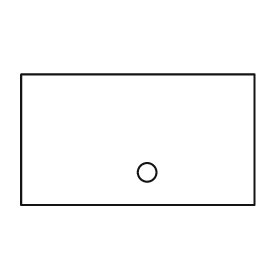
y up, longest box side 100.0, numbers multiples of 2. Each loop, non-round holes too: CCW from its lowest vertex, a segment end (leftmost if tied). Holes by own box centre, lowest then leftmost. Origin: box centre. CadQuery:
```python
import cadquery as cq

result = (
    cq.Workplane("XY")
    .moveTo(-50.0, -28.0)
    .lineTo(50.0, -28.0)
    .lineTo(50.0, 28.0)
    .lineTo(-50.0, 28.0)
    .close()
    .moveTo(4.0, -14.0)
    .circle(4.0)
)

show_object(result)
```